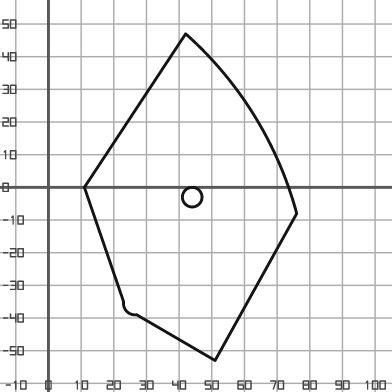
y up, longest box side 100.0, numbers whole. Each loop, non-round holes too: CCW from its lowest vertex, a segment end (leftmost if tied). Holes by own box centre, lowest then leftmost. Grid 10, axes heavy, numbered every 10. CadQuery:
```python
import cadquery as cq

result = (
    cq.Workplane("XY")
    .moveTo(51.0, -53.0)
    .lineTo(76.0, -8.0)
    .threePointArc((63.0, 22.0), (42.0, 47.0))
    .lineTo(11.0, 0.0)
    .lineTo(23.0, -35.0)
    .threePointArc((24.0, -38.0), (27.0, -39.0))
    .close()
    .moveTo(44.0, -3.0)
    .circle(3.0)
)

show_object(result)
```